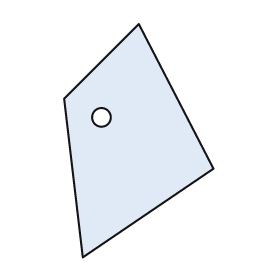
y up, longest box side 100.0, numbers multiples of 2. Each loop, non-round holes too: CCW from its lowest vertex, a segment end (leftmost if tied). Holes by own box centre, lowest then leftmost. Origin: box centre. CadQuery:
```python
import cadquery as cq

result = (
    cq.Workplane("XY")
    .moveTo(-24.0, -50.0)
    .lineTo(32.0, -12.0)
    .lineTo(0.0, 50.0)
    .lineTo(-32.0, 18.0)
    .close()
    .moveTo(-16.0, 10.0)
    .circle(4.0)
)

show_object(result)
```